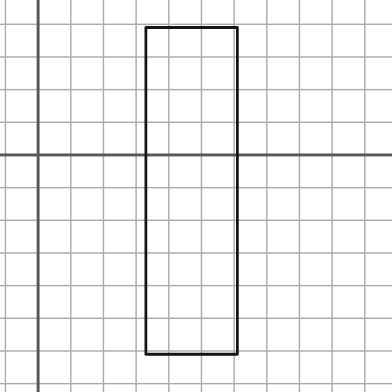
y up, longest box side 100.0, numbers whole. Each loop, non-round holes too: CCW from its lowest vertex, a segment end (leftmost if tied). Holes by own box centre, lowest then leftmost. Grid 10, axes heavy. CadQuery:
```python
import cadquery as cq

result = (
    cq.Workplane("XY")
    .moveTo(33.0, -61.0)
    .lineTo(61.0, -61.0)
    .lineTo(61.0, 39.0)
    .lineTo(33.0, 39.0)
    .close()
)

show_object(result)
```